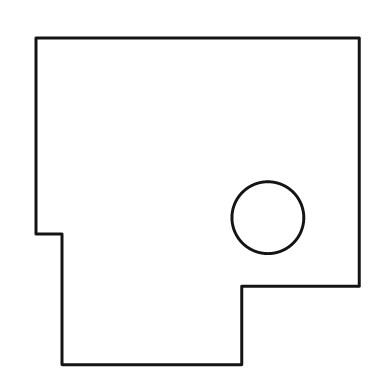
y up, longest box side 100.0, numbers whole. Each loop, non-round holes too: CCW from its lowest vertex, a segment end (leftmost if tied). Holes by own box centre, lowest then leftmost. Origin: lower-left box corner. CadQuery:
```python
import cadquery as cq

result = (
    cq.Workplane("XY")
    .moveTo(8.0, 0.0)
    .lineTo(63.0, 0.0)
    .lineTo(63.0, 24.0)
    .lineTo(99.0, 24.0)
    .lineTo(99.0, 100.0)
    .lineTo(0.0, 100.0)
    .lineTo(0.0, 40.0)
    .lineTo(8.0, 40.0)
    .close()
    .moveTo(71.0, 45.0)
    .circle(11.0)
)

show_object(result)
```